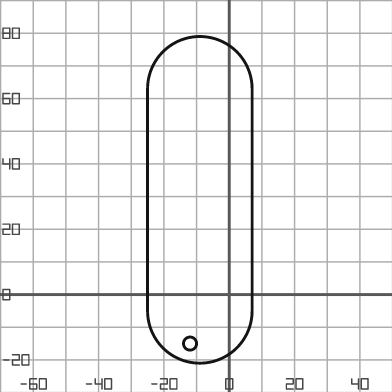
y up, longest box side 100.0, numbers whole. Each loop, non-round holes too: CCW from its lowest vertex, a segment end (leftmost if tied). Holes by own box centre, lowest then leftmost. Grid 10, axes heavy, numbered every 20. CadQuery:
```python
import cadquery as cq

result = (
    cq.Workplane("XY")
    .moveTo(-25.0, -5.0)
    .threePointArc((-9.0, -21.0), (7.0, -5.0))
    .lineTo(7.0, 63.0)
    .threePointArc((-9.0, 79.0), (-25.0, 63.0))
    .close()
    .moveTo(-12.0, -15.0)
    .circle(2.0)
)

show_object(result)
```